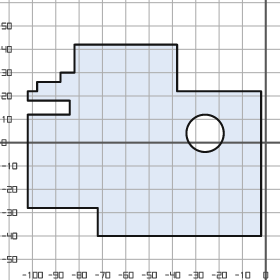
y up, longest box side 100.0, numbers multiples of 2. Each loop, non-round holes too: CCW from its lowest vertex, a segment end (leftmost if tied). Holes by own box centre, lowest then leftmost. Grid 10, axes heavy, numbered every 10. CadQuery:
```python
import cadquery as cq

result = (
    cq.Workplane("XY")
    .moveTo(-72.0, -40.0)
    .lineTo(-2.0, -40.0)
    .lineTo(-2.0, 22.0)
    .lineTo(-38.0, 22.0)
    .lineTo(-38.0, 42.0)
    .lineTo(-82.0, 42.0)
    .lineTo(-82.0, 30.0)
    .lineTo(-88.0, 30.0)
    .lineTo(-88.0, 26.0)
    .lineTo(-98.0, 26.0)
    .lineTo(-98.0, 22.0)
    .lineTo(-102.0, 22.0)
    .lineTo(-102.0, 18.0)
    .lineTo(-84.0, 18.0)
    .lineTo(-84.0, 12.0)
    .lineTo(-102.0, 12.0)
    .lineTo(-102.0, -28.0)
    .lineTo(-72.0, -28.0)
    .close()
    .moveTo(-26.0, 4.0)
    .circle(8.0)
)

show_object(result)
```